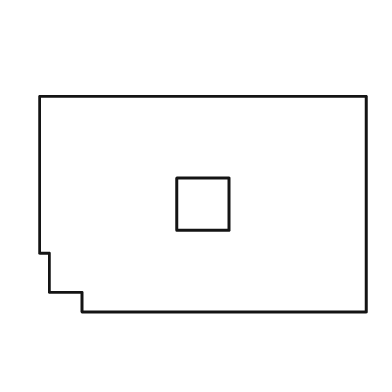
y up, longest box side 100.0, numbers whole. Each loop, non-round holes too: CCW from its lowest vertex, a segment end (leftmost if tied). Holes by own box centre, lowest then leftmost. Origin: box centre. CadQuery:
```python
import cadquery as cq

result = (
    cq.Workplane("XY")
    .moveTo(-37.0, -33.0)
    .lineTo(50.0, -33.0)
    .lineTo(50.0, 33.0)
    .lineTo(-50.0, 33.0)
    .lineTo(-50.0, -15.0)
    .lineTo(-47.0, -15.0)
    .lineTo(-47.0, -27.0)
    .lineTo(-37.0, -27.0)
    .close()
    .moveTo(-8.0, -8.0)
    .lineTo(8.0, -8.0)
    .lineTo(8.0, 8.0)
    .lineTo(-8.0, 8.0)
    .close()
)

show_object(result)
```